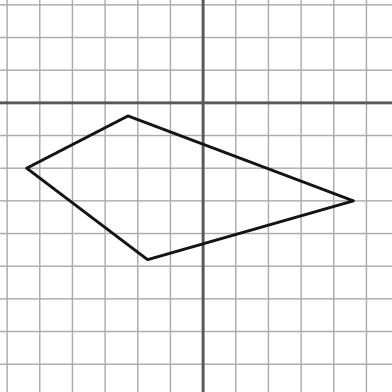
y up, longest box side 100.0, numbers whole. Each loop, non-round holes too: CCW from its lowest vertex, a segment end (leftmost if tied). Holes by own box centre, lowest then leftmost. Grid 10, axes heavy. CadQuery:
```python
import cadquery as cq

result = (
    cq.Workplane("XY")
    .moveTo(-17.0, -48.0)
    .lineTo(46.0, -30.0)
    .lineTo(-23.0, -4.0)
    .lineTo(-54.0, -20.0)
    .close()
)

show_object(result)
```